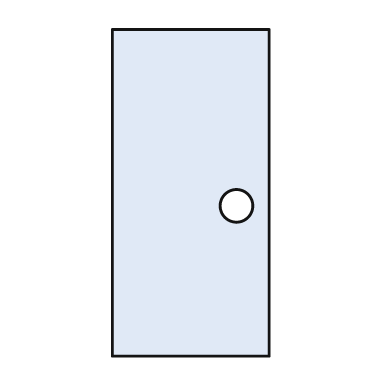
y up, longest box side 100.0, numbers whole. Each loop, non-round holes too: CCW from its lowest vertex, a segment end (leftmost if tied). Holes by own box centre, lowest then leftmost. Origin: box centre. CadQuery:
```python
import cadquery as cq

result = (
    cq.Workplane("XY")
    .moveTo(-24.0, -50.0)
    .lineTo(24.0, -50.0)
    .lineTo(24.0, 50.0)
    .lineTo(-24.0, 50.0)
    .close()
    .moveTo(14.0, -4.0)
    .circle(5.0)
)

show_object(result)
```